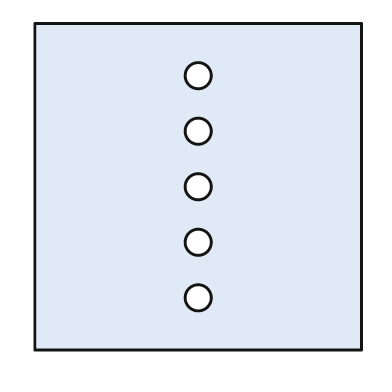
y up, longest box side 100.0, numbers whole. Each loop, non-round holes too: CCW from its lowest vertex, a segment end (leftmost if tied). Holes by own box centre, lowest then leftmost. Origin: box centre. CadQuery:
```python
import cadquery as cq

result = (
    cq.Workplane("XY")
    .moveTo(-50.0, -50.0)
    .lineTo(50.0, -50.0)
    .lineTo(50.0, 50.0)
    .lineTo(-50.0, 50.0)
    .close()
    .moveTo(0.0, -34.0)
    .circle(4.0)
    .moveTo(0.0, -17.0)
    .circle(4.0)
    .moveTo(0.0, 0.0)
    .circle(4.0)
    .moveTo(0.0, 17.0)
    .circle(4.0)
    .moveTo(0.0, 34.0)
    .circle(4.0)
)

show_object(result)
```